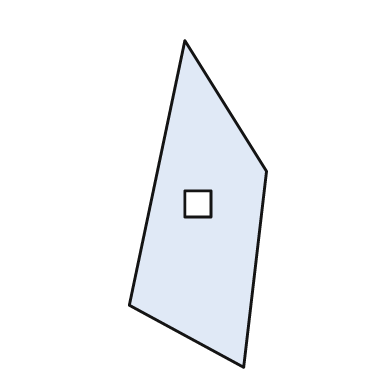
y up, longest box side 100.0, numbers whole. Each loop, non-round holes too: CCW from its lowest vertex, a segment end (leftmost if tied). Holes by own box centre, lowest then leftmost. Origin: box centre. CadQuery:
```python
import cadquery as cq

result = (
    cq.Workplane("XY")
    .moveTo(14.0, -50.0)
    .lineTo(21.0, 10.0)
    .lineTo(-4.0, 50.0)
    .lineTo(-21.0, -31.0)
    .close()
    .moveTo(-4.0, -4.0)
    .lineTo(4.0, -4.0)
    .lineTo(4.0, 4.0)
    .lineTo(-4.0, 4.0)
    .close()
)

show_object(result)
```